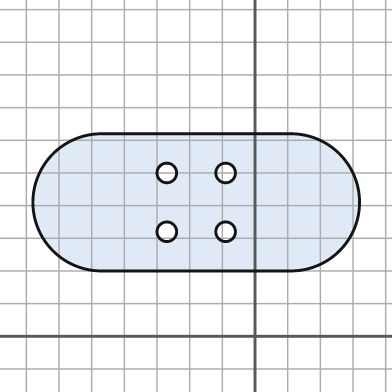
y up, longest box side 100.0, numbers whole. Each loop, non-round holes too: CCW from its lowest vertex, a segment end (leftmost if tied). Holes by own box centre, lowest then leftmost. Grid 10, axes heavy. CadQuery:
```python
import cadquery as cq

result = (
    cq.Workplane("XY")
    .moveTo(-47.0, 20.0)
    .lineTo(11.0, 20.0)
    .threePointArc((32.0, 41.0), (11.0, 62.0))
    .lineTo(-47.0, 62.0)
    .threePointArc((-68.0, 41.0), (-47.0, 20.0))
    .close()
    .moveTo(-27.0, 32.0)
    .circle(3.0)
    .moveTo(-9.0, 32.0)
    .circle(3.0)
    .moveTo(-27.0, 50.0)
    .circle(3.0)
    .moveTo(-9.0, 50.0)
    .circle(3.0)
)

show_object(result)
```